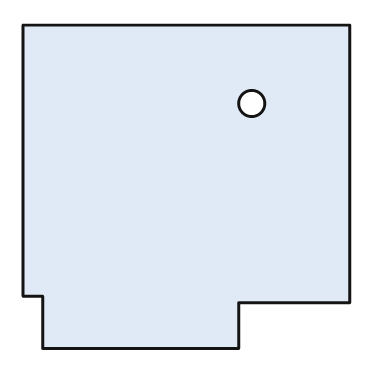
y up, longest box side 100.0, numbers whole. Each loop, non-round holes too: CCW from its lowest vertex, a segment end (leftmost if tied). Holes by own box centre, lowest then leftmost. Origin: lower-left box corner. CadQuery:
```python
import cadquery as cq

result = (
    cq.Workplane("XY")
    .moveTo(6.0, 0.0)
    .lineTo(66.0, 0.0)
    .lineTo(66.0, 14.0)
    .lineTo(100.0, 14.0)
    .lineTo(100.0, 99.0)
    .lineTo(0.0, 99.0)
    .lineTo(0.0, 16.0)
    .lineTo(6.0, 16.0)
    .close()
    .moveTo(70.0, 75.0)
    .circle(4.0)
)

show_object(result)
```